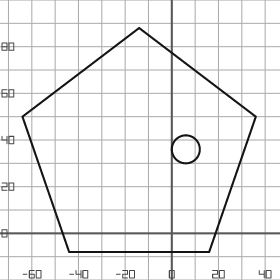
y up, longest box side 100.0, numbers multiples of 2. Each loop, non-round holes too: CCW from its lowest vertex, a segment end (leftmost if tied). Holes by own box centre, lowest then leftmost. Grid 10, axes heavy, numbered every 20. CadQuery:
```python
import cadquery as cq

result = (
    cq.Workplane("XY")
    .moveTo(-44.0, -8.0)
    .lineTo(16.0, -8.0)
    .lineTo(36.0, 50.0)
    .lineTo(-14.0, 88.0)
    .lineTo(-64.0, 50.0)
    .close()
    .moveTo(6.0, 36.0)
    .circle(6.0)
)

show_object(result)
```